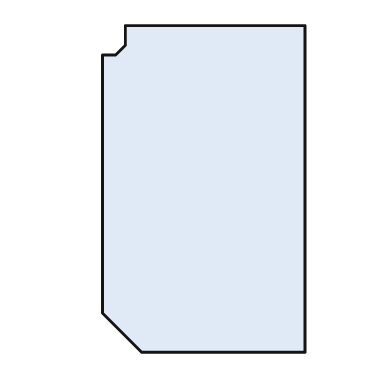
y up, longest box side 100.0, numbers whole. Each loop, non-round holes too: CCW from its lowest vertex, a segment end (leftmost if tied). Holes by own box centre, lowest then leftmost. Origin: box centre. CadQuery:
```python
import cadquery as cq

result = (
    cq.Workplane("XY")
    .moveTo(-19.0, -50.0)
    .lineTo(31.0, -50.0)
    .lineTo(31.0, 50.0)
    .lineTo(-24.0, 50.0)
    .lineTo(-24.0, 44.0)
    .lineTo(-27.0, 41.0)
    .lineTo(-31.0, 41.0)
    .lineTo(-31.0, -38.0)
    .close()
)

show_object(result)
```